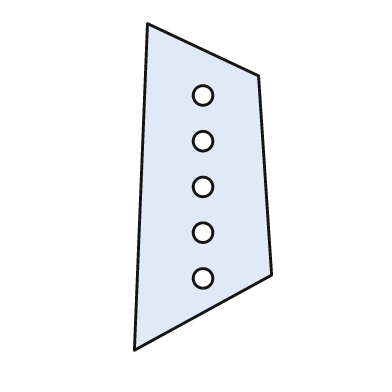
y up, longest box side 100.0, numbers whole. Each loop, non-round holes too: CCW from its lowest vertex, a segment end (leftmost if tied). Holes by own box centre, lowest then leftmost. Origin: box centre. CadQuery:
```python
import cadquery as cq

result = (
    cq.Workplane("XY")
    .moveTo(-21.0, -50.0)
    .lineTo(21.0, -27.0)
    .lineTo(17.0, 34.0)
    .lineTo(-17.0, 50.0)
    .close()
    .moveTo(0.0, -28.0)
    .circle(3.0)
    .moveTo(0.0, -14.0)
    .circle(3.0)
    .moveTo(0.0, 0.0)
    .circle(3.0)
    .moveTo(0.0, 14.0)
    .circle(3.0)
    .moveTo(0.0, 28.0)
    .circle(3.0)
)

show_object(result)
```